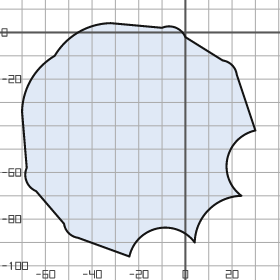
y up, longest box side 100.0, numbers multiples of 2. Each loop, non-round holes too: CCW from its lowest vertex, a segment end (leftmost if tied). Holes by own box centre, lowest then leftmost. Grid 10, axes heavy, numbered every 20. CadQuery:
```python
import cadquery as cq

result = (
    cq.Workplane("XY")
    .moveTo(-24.0, -96.0)
    .threePointArc((-12.0, -84.0), (4.0, -90.0))
    .threePointArc((10.0, -76.0), (24.0, -70.0))
    .threePointArc((18.0, -54.0), (30.0, -42.0))
    .lineTo(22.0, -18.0)
    .threePointArc((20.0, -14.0), (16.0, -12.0))
    .lineTo(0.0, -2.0)
    .threePointArc((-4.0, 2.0), (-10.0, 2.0))
    .lineTo(-32.0, 4.0)
    .threePointArc((-46.0, 0.0), (-56.0, -10.0))
    .threePointArc((-66.0, -20.0), (-70.0, -34.0))
    .lineTo(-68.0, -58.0)
    .threePointArc((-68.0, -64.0), (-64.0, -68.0))
    .lineTo(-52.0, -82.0)
    .threePointArc((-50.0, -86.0), (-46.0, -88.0))
    .close()
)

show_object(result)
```